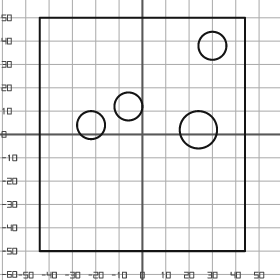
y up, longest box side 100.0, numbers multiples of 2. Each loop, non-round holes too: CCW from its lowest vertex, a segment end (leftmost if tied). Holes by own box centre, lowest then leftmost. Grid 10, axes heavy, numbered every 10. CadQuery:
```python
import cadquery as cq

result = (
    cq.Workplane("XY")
    .moveTo(-44.0, -50.0)
    .lineTo(44.0, -50.0)
    .lineTo(44.0, 50.0)
    .lineTo(-44.0, 50.0)
    .close()
    .moveTo(24.0, 2.0)
    .circle(8.0)
    .moveTo(-22.0, 4.0)
    .circle(6.0)
    .moveTo(-6.0, 12.0)
    .circle(6.0)
    .moveTo(30.0, 38.0)
    .circle(6.0)
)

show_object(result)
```